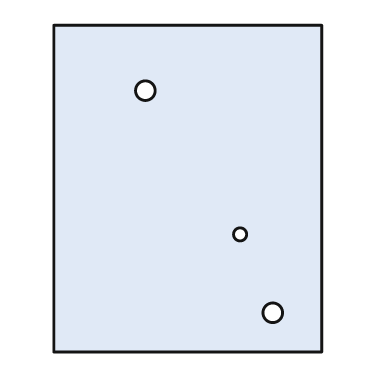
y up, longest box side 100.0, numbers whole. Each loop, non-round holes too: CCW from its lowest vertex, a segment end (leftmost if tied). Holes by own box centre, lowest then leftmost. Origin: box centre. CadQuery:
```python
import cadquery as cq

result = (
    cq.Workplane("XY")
    .moveTo(-41.0, -50.0)
    .lineTo(41.0, -50.0)
    .lineTo(41.0, 50.0)
    .lineTo(-41.0, 50.0)
    .close()
    .moveTo(26.0, -38.0)
    .circle(3.0)
    .moveTo(16.0, -14.0)
    .circle(2.0)
    .moveTo(-13.0, 30.0)
    .circle(3.0)
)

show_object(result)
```